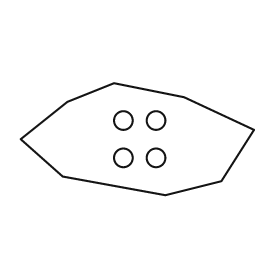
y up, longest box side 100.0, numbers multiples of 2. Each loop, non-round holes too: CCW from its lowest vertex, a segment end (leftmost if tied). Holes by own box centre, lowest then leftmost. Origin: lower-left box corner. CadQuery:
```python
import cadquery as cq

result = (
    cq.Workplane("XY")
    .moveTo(62.0, 0.0)
    .lineTo(86.0, 6.0)
    .lineTo(100.0, 28.0)
    .lineTo(70.0, 42.0)
    .lineTo(40.0, 48.0)
    .lineTo(20.0, 40.0)
    .lineTo(0.0, 24.0)
    .lineTo(18.0, 8.0)
    .close()
    .moveTo(44.0, 16.0)
    .circle(4.0)
    .moveTo(58.0, 16.0)
    .circle(4.0)
    .moveTo(44.0, 32.0)
    .circle(4.0)
    .moveTo(58.0, 32.0)
    .circle(4.0)
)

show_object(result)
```